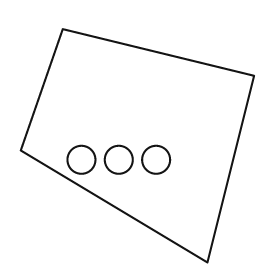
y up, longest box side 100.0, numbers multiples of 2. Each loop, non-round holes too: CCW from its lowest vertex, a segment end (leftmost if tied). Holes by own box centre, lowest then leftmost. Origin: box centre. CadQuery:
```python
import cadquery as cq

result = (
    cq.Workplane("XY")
    .moveTo(30.0, -50.0)
    .lineTo(50.0, 30.0)
    .lineTo(-32.0, 50.0)
    .lineTo(-50.0, -2.0)
    .close()
    .moveTo(-24.0, -6.0)
    .circle(6.0)
    .moveTo(-8.0, -6.0)
    .circle(6.0)
    .moveTo(8.0, -6.0)
    .circle(6.0)
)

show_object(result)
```